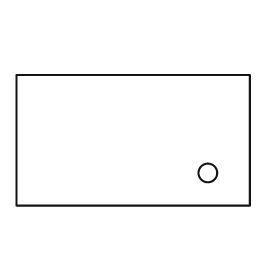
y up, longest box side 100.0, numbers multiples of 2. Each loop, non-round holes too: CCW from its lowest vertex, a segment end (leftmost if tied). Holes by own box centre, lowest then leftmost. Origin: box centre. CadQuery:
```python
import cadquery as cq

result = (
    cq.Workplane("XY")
    .moveTo(-50.0, -28.0)
    .lineTo(50.0, -28.0)
    .lineTo(50.0, 28.0)
    .lineTo(-50.0, 28.0)
    .close()
    .moveTo(32.0, -14.0)
    .circle(4.0)
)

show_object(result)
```